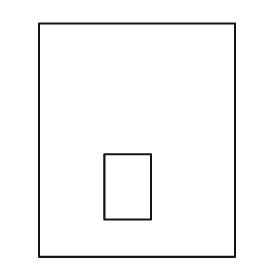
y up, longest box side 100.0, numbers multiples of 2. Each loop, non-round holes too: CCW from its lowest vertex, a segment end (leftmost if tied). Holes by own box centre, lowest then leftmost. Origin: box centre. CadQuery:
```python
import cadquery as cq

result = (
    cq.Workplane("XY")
    .moveTo(-42.0, -50.0)
    .lineTo(42.0, -50.0)
    .lineTo(42.0, 50.0)
    .lineTo(-42.0, 50.0)
    .close()
    .moveTo(-14.0, -34.0)
    .lineTo(6.0, -34.0)
    .lineTo(6.0, -6.0)
    .lineTo(-14.0, -6.0)
    .close()
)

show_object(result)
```